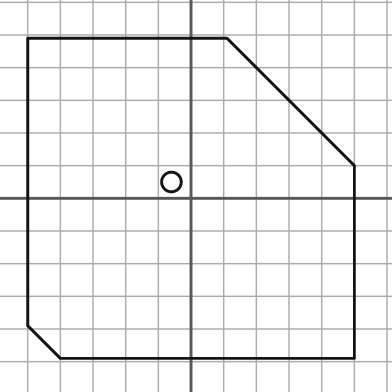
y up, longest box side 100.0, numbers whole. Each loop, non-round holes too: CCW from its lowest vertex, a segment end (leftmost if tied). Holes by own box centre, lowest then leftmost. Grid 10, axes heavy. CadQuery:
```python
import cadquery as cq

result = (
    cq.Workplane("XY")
    .moveTo(-40.0, -49.0)
    .lineTo(50.0, -49.0)
    .lineTo(50.0, 10.0)
    .lineTo(11.0, 49.0)
    .lineTo(-50.0, 49.0)
    .lineTo(-50.0, -39.0)
    .close()
    .moveTo(-6.0, 5.0)
    .circle(3.0)
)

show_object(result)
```